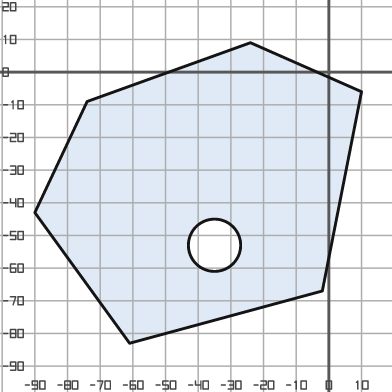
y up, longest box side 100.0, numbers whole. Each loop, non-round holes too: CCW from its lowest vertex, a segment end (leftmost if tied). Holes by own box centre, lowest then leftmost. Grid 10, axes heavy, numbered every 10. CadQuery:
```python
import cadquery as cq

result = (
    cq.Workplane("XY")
    .moveTo(-61.0, -83.0)
    .lineTo(-2.0, -67.0)
    .lineTo(10.0, -6.0)
    .lineTo(-24.0, 9.0)
    .lineTo(-74.0, -9.0)
    .lineTo(-90.0, -43.0)
    .close()
    .moveTo(-35.0, -53.0)
    .circle(8.0)
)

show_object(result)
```